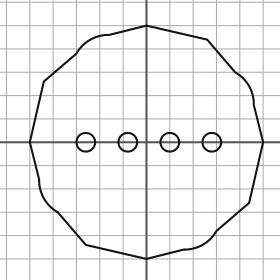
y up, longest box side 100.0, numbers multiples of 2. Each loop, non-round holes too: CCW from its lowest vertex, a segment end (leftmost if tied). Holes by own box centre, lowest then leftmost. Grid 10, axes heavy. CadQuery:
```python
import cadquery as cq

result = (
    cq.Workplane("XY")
    .moveTo(0.0, -50.0)
    .lineTo(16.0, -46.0)
    .threePointArc((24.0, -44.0), (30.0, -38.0))
    .lineTo(44.0, -26.0)
    .lineTo(50.0, 0.0)
    .lineTo(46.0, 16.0)
    .threePointArc((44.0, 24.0), (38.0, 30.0))
    .lineTo(26.0, 44.0)
    .lineTo(0.0, 50.0)
    .lineTo(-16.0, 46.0)
    .threePointArc((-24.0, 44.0), (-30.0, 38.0))
    .lineTo(-44.0, 26.0)
    .lineTo(-50.0, 0.0)
    .lineTo(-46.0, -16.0)
    .threePointArc((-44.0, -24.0), (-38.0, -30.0))
    .lineTo(-26.0, -44.0)
    .close()
    .moveTo(-26.0, 0.0)
    .circle(4.0)
    .moveTo(-8.0, 0.0)
    .circle(4.0)
    .moveTo(10.0, 0.0)
    .circle(4.0)
    .moveTo(28.0, 0.0)
    .circle(4.0)
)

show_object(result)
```